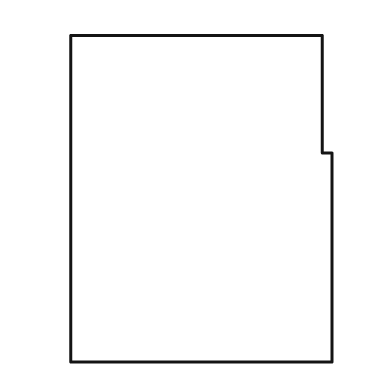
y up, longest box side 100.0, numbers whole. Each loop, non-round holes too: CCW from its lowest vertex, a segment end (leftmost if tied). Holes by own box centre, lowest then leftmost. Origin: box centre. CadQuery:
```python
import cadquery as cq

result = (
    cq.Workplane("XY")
    .moveTo(-40.0, -50.0)
    .lineTo(40.0, -50.0)
    .lineTo(40.0, 14.0)
    .lineTo(37.0, 14.0)
    .lineTo(37.0, 50.0)
    .lineTo(-40.0, 50.0)
    .close()
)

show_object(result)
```